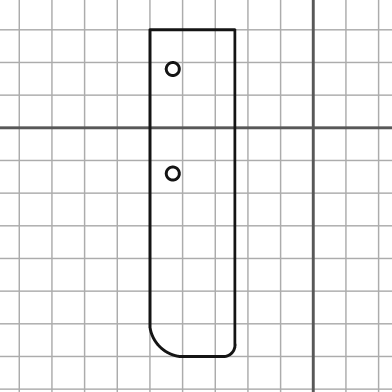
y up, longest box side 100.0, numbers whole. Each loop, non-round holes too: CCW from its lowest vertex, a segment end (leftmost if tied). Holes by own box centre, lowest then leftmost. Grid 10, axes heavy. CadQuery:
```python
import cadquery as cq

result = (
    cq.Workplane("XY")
    .moveTo(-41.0, -70.0)
    .lineTo(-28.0, -70.0)
    .threePointArc((-25.0, -69.0), (-24.0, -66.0))
    .lineTo(-24.0, 30.0)
    .lineTo(-50.0, 30.0)
    .lineTo(-50.0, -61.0)
    .threePointArc((-47.0, -67.0), (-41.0, -70.0))
    .close()
    .moveTo(-43.0, -14.0)
    .circle(2.0)
    .moveTo(-43.0, 18.0)
    .circle(2.0)
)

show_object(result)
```